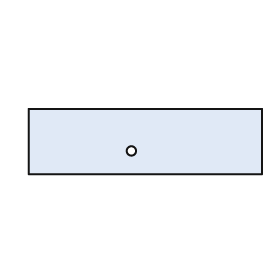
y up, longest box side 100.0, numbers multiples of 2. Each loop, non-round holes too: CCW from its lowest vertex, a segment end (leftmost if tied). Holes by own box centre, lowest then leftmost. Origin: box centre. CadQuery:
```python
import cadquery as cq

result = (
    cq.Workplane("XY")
    .moveTo(-50.0, -14.0)
    .lineTo(50.0, -14.0)
    .lineTo(50.0, 14.0)
    .lineTo(-50.0, 14.0)
    .close()
    .moveTo(-6.0, -4.0)
    .circle(2.0)
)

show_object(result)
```